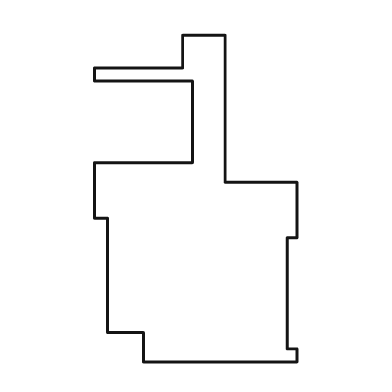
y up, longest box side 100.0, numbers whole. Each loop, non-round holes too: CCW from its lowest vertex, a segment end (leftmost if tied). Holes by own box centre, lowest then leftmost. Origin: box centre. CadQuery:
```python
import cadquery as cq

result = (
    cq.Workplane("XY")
    .moveTo(-16.0, -50.0)
    .lineTo(31.0, -50.0)
    .lineTo(31.0, -46.0)
    .lineTo(28.0, -46.0)
    .lineTo(28.0, -12.0)
    .lineTo(31.0, -12.0)
    .lineTo(31.0, 5.0)
    .lineTo(9.0, 5.0)
    .lineTo(9.0, 50.0)
    .lineTo(-4.0, 50.0)
    .lineTo(-4.0, 40.0)
    .lineTo(-31.0, 40.0)
    .lineTo(-31.0, 36.0)
    .lineTo(-1.0, 36.0)
    .lineTo(-1.0, 11.0)
    .lineTo(-31.0, 11.0)
    .lineTo(-31.0, -6.0)
    .lineTo(-27.0, -6.0)
    .lineTo(-27.0, -41.0)
    .lineTo(-16.0, -41.0)
    .close()
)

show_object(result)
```